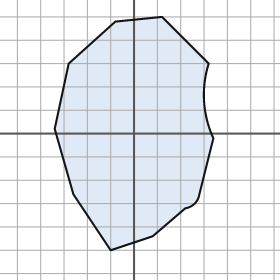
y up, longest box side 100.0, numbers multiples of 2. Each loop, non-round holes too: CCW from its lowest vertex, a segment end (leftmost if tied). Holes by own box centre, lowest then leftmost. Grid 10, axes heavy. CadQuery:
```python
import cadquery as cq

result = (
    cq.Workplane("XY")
    .moveTo(-10.0, -50.0)
    .lineTo(8.0, -44.0)
    .lineTo(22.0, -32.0)
    .threePointArc((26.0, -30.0), (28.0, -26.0))
    .lineTo(34.0, -2.0)
    .threePointArc((30.0, 14.0), (32.0, 30.0))
    .lineTo(12.0, 50.0)
    .lineTo(-8.0, 48.0)
    .lineTo(-28.0, 30.0)
    .lineTo(-34.0, 2.0)
    .lineTo(-26.0, -26.0)
    .close()
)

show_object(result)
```